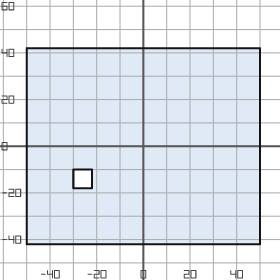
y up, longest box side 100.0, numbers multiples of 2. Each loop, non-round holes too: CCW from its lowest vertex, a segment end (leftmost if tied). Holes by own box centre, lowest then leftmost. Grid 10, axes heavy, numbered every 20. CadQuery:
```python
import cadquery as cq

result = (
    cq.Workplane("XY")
    .moveTo(-50.0, -42.0)
    .lineTo(50.0, -42.0)
    .lineTo(50.0, 42.0)
    .lineTo(-50.0, 42.0)
    .close()
    .moveTo(-30.0, -18.0)
    .lineTo(-22.0, -18.0)
    .lineTo(-22.0, -10.0)
    .lineTo(-30.0, -10.0)
    .close()
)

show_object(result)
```